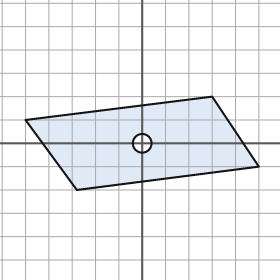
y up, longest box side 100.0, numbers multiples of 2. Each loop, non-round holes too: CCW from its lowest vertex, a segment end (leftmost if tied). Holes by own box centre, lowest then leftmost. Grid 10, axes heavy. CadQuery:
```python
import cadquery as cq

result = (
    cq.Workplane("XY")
    .moveTo(-28.0, -20.0)
    .lineTo(50.0, -10.0)
    .lineTo(30.0, 20.0)
    .lineTo(-50.0, 10.0)
    .close()
    .moveTo(0.0, 0.0)
    .circle(4.0)
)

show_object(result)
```